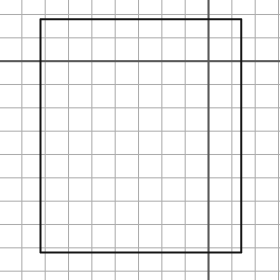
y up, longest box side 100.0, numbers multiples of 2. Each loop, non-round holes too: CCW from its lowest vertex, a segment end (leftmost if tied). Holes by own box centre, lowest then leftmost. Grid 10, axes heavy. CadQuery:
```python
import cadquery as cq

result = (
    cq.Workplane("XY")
    .moveTo(-72.0, -82.0)
    .lineTo(14.0, -82.0)
    .lineTo(14.0, 18.0)
    .lineTo(-72.0, 18.0)
    .close()
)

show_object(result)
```